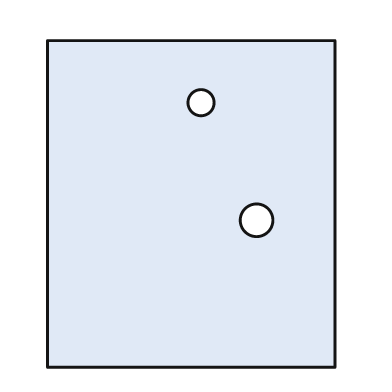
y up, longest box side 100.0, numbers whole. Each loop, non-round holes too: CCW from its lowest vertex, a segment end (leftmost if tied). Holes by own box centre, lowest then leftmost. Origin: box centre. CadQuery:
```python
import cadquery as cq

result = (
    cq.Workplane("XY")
    .moveTo(-44.0, -50.0)
    .lineTo(44.0, -50.0)
    .lineTo(44.0, 50.0)
    .lineTo(-44.0, 50.0)
    .close()
    .moveTo(20.0, -5.0)
    .circle(5.0)
    .moveTo(3.0, 31.0)
    .circle(4.0)
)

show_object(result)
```